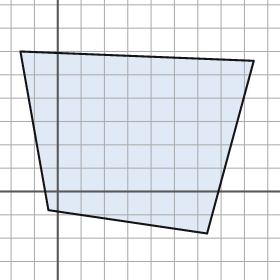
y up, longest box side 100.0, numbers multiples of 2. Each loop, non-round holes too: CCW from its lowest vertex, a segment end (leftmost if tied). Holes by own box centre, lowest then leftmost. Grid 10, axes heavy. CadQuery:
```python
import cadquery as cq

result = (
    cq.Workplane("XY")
    .moveTo(64.0, -18.0)
    .lineTo(84.0, 56.0)
    .lineTo(-16.0, 60.0)
    .lineTo(-4.0, -8.0)
    .close()
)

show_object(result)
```